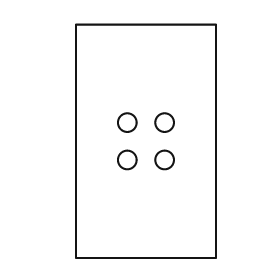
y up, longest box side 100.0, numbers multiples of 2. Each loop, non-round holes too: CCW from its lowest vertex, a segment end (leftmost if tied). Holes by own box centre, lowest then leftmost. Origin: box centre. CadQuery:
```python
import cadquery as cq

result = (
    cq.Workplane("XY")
    .moveTo(-30.0, -50.0)
    .lineTo(30.0, -50.0)
    .lineTo(30.0, 50.0)
    .lineTo(-30.0, 50.0)
    .close()
    .moveTo(-8.0, -8.0)
    .circle(4.0)
    .moveTo(8.0, -8.0)
    .circle(4.0)
    .moveTo(-8.0, 8.0)
    .circle(4.0)
    .moveTo(8.0, 8.0)
    .circle(4.0)
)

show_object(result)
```